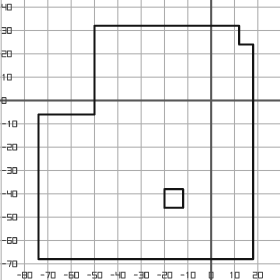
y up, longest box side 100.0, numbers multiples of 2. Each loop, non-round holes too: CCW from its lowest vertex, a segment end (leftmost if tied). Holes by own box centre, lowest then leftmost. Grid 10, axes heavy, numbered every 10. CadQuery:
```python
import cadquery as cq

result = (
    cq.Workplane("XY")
    .moveTo(-74.0, -68.0)
    .lineTo(18.0, -68.0)
    .lineTo(18.0, 24.0)
    .lineTo(12.0, 24.0)
    .lineTo(12.0, 32.0)
    .lineTo(-50.0, 32.0)
    .lineTo(-50.0, -6.0)
    .lineTo(-74.0, -6.0)
    .close()
    .moveTo(-20.0, -46.0)
    .lineTo(-12.0, -46.0)
    .lineTo(-12.0, -38.0)
    .lineTo(-20.0, -38.0)
    .close()
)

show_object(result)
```